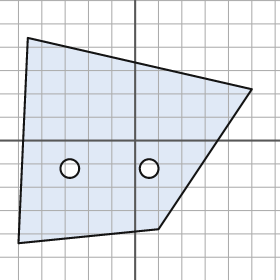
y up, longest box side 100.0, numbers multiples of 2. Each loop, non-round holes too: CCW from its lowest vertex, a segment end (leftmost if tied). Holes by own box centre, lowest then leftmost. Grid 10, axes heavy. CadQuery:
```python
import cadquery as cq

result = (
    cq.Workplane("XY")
    .moveTo(-50.0, -44.0)
    .lineTo(10.0, -38.0)
    .lineTo(50.0, 22.0)
    .lineTo(-46.0, 44.0)
    .close()
    .moveTo(-28.0, -12.0)
    .circle(4.0)
    .moveTo(6.0, -12.0)
    .circle(4.0)
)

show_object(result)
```